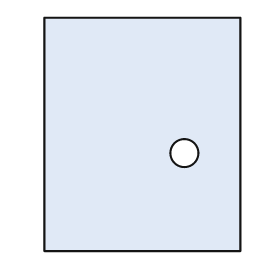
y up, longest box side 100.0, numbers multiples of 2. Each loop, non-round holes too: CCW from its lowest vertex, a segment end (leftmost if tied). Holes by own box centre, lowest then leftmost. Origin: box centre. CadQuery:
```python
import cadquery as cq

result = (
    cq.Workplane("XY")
    .moveTo(-42.0, -50.0)
    .lineTo(42.0, -50.0)
    .lineTo(42.0, 50.0)
    .lineTo(-42.0, 50.0)
    .close()
    .moveTo(18.0, -8.0)
    .circle(6.0)
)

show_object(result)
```